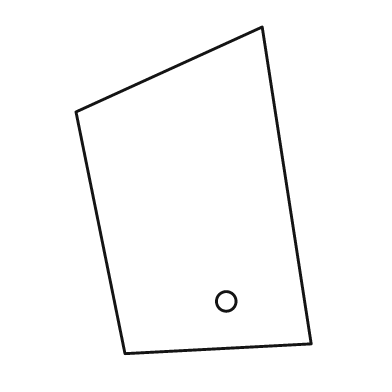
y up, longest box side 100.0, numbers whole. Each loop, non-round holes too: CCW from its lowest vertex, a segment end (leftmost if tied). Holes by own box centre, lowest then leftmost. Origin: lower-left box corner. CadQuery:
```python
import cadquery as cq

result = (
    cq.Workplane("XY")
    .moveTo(15.0, 0.0)
    .lineTo(72.0, 3.0)
    .lineTo(57.0, 100.0)
    .lineTo(0.0, 74.0)
    .close()
    .moveTo(46.0, 16.0)
    .circle(3.0)
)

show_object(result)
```